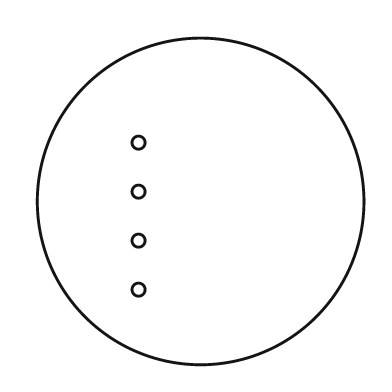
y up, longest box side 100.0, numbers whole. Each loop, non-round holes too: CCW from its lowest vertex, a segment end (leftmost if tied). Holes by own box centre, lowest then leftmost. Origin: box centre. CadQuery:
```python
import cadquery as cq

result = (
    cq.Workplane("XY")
    .moveTo(0.0, 0.0)
    .circle(50.0)
    .moveTo(-19.0, -27.0)
    .circle(2.0)
    .moveTo(-19.0, -12.0)
    .circle(2.0)
    .moveTo(-19.0, 3.0)
    .circle(2.0)
    .moveTo(-19.0, 18.0)
    .circle(2.0)
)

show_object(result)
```